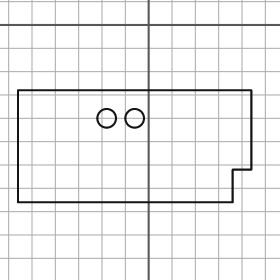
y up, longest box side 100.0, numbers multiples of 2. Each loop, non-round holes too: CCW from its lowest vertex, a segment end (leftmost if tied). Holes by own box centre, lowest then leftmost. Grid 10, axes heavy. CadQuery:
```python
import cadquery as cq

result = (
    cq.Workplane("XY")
    .moveTo(-56.0, -76.0)
    .lineTo(36.0, -76.0)
    .lineTo(36.0, -62.0)
    .lineTo(44.0, -62.0)
    .lineTo(44.0, -28.0)
    .lineTo(-56.0, -28.0)
    .close()
    .moveTo(-18.0, -40.0)
    .circle(4.0)
    .moveTo(-6.0, -40.0)
    .circle(4.0)
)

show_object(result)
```